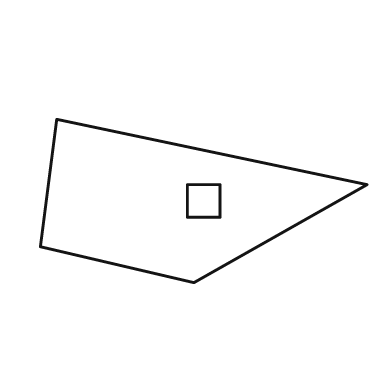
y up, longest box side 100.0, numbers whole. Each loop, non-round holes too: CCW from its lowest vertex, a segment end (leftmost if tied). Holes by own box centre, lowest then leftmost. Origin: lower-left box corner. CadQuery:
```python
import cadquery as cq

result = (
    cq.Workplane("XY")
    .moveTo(47.0, 0.0)
    .lineTo(100.0, 30.0)
    .lineTo(5.0, 50.0)
    .lineTo(0.0, 11.0)
    .close()
    .moveTo(45.0, 20.0)
    .lineTo(55.0, 20.0)
    .lineTo(55.0, 30.0)
    .lineTo(45.0, 30.0)
    .close()
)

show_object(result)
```